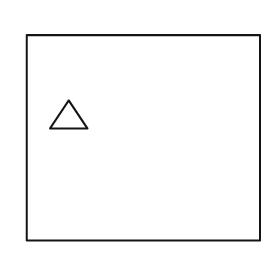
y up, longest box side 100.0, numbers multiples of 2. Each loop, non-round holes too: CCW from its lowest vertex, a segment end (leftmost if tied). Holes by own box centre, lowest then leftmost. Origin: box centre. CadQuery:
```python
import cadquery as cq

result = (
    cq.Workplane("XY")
    .moveTo(-50.0, -44.0)
    .lineTo(50.0, -44.0)
    .lineTo(50.0, 44.0)
    .lineTo(-50.0, 44.0)
    .close()
    .moveTo(-40.0, 4.0)
    .lineTo(-24.0, 4.0)
    .lineTo(-32.0, 16.0)
    .close()
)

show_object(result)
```